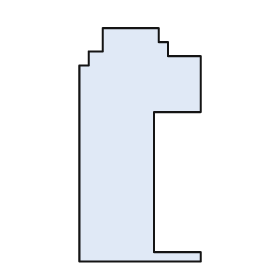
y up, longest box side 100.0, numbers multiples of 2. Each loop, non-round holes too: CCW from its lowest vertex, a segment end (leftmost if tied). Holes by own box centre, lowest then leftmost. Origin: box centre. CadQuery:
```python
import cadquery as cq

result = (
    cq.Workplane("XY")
    .moveTo(-26.0, -50.0)
    .lineTo(26.0, -50.0)
    .lineTo(26.0, -46.0)
    .lineTo(6.0, -46.0)
    .lineTo(6.0, 14.0)
    .lineTo(26.0, 14.0)
    .lineTo(26.0, 38.0)
    .lineTo(12.0, 38.0)
    .lineTo(12.0, 44.0)
    .lineTo(8.0, 44.0)
    .lineTo(8.0, 50.0)
    .lineTo(-16.0, 50.0)
    .lineTo(-16.0, 40.0)
    .lineTo(-22.0, 40.0)
    .lineTo(-22.0, 34.0)
    .lineTo(-26.0, 34.0)
    .close()
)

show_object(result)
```